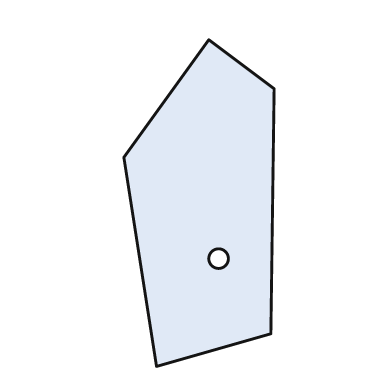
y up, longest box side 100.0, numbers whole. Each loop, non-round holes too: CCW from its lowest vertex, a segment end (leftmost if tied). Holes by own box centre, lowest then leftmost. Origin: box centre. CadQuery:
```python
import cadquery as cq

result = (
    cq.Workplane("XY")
    .moveTo(-13.0, -50.0)
    .lineTo(22.0, -40.0)
    .lineTo(23.0, 35.0)
    .lineTo(3.0, 50.0)
    .lineTo(-23.0, 14.0)
    .close()
    .moveTo(6.0, -17.0)
    .circle(3.0)
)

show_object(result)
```